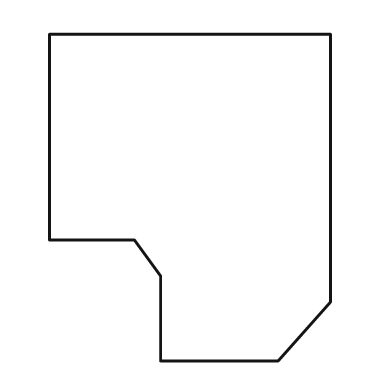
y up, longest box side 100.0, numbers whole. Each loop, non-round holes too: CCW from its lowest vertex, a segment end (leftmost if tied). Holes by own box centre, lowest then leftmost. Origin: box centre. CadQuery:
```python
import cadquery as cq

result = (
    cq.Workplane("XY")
    .moveTo(-9.0, -50.0)
    .lineTo(27.0, -50.0)
    .lineTo(43.0, -32.0)
    .lineTo(43.0, 50.0)
    .lineTo(-43.0, 50.0)
    .lineTo(-43.0, -13.0)
    .lineTo(-17.0, -13.0)
    .lineTo(-9.0, -24.0)
    .close()
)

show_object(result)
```